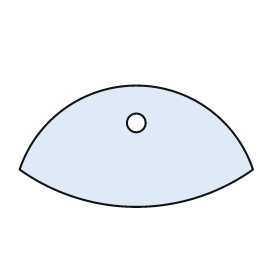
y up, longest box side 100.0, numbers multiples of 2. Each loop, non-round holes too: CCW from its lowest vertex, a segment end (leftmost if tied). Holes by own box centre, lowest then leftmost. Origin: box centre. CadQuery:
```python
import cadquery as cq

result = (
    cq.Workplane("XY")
    .moveTo(-50.0, -10.0)
    .threePointArc((0.0, -26.0), (50.0, -10.0))
    .threePointArc((0.0, 26.0), (-50.0, -10.0))
    .close()
    .moveTo(0.0, 10.0)
    .circle(4.0)
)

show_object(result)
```